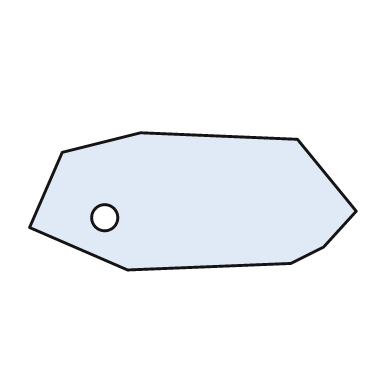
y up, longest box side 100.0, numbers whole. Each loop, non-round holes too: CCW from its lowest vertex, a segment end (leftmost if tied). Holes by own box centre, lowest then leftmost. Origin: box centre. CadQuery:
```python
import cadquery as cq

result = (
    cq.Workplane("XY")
    .moveTo(-20.0, -21.0)
    .lineTo(30.0, -19.0)
    .lineTo(40.0, -14.0)
    .lineTo(50.0, -3.0)
    .lineTo(32.0, 19.0)
    .lineTo(-16.0, 21.0)
    .lineTo(-40.0, 15.0)
    .lineTo(-50.0, -8.0)
    .close()
    .moveTo(-27.0, -5.0)
    .circle(4.0)
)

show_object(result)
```